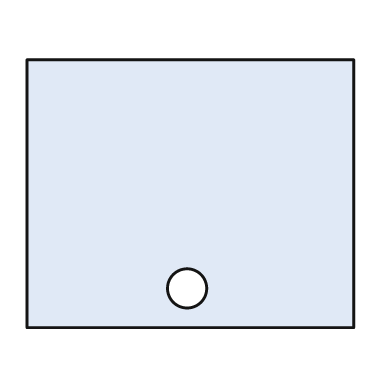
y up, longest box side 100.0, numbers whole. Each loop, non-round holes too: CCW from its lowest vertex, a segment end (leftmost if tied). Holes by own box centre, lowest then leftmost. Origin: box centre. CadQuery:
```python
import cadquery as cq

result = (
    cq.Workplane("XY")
    .moveTo(-50.0, -41.0)
    .lineTo(50.0, -41.0)
    .lineTo(50.0, 41.0)
    .lineTo(-50.0, 41.0)
    .close()
    .moveTo(-1.0, -29.0)
    .circle(6.0)
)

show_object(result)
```